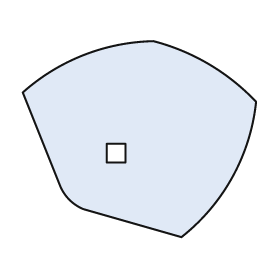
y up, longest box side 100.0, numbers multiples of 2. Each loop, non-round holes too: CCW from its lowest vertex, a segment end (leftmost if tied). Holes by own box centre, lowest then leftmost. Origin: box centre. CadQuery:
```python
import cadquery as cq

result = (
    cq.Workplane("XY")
    .moveTo(18.0, -42.0)
    .threePointArc((40.0, -16.0), (50.0, 16.0))
    .threePointArc((30.0, 32.0), (6.0, 42.0))
    .threePointArc((-24.0, 36.0), (-50.0, 20.0))
    .lineTo(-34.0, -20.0)
    .threePointArc((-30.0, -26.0), (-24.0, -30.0))
    .close()
    .moveTo(-14.0, -10.0)
    .lineTo(-6.0, -10.0)
    .lineTo(-6.0, -2.0)
    .lineTo(-14.0, -2.0)
    .close()
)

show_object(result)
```